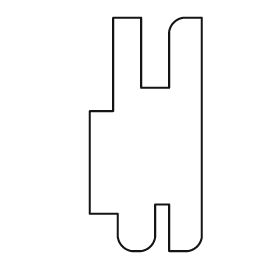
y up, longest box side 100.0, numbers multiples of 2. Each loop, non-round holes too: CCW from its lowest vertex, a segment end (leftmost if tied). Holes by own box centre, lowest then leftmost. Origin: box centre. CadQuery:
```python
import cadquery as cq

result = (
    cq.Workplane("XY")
    .moveTo(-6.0, -50.0)
    .lineTo(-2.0, -50.0)
    .threePointArc((2.0, -48.0), (4.0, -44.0))
    .lineTo(4.0, -30.0)
    .lineTo(10.0, -30.0)
    .lineTo(10.0, -50.0)
    .lineTo(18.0, -50.0)
    .threePointArc((22.0, -48.0), (24.0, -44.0))
    .lineTo(24.0, 50.0)
    .lineTo(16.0, 50.0)
    .threePointArc((12.0, 48.0), (10.0, 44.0))
    .lineTo(10.0, 20.0)
    .lineTo(-2.0, 20.0)
    .lineTo(-2.0, 50.0)
    .lineTo(-14.0, 50.0)
    .lineTo(-14.0, 10.0)
    .lineTo(-24.0, 10.0)
    .lineTo(-24.0, -34.0)
    .lineTo(-12.0, -34.0)
    .lineTo(-12.0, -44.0)
    .threePointArc((-10.0, -48.0), (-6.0, -50.0))
    .close()
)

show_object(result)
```